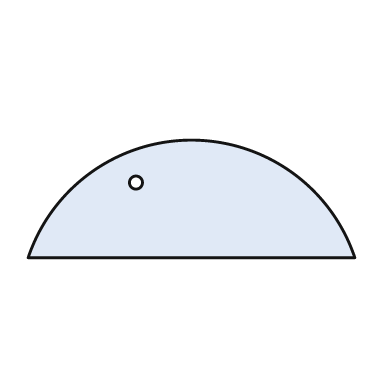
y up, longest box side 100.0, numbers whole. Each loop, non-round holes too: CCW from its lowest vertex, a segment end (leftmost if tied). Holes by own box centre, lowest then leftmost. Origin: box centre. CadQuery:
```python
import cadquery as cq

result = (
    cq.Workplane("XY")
    .moveTo(-50.0, -18.0)
    .lineTo(50.0, -18.0)
    .threePointArc((0.0, 18.0), (-50.0, -18.0))
    .close()
    .moveTo(-17.0, 5.0)
    .circle(2.0)
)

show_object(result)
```